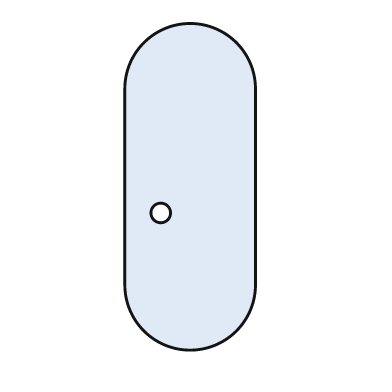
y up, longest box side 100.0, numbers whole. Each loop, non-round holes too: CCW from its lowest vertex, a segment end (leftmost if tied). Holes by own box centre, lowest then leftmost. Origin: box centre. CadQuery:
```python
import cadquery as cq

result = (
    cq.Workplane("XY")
    .moveTo(-20.0, -30.0)
    .threePointArc((0.0, -50.0), (20.0, -30.0))
    .lineTo(20.0, 30.0)
    .threePointArc((0.0, 50.0), (-20.0, 30.0))
    .close()
    .moveTo(-9.0, -8.0)
    .circle(3.0)
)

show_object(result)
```